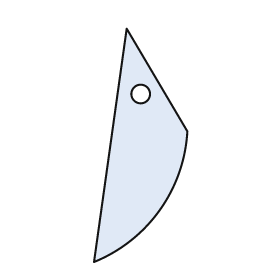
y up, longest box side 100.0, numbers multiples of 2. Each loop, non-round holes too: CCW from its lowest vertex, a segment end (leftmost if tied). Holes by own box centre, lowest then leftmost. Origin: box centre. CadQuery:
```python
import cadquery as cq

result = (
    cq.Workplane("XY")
    .moveTo(-20.0, -50.0)
    .threePointArc((8.0, -28.0), (20.0, 6.0))
    .lineTo(-6.0, 50.0)
    .close()
    .moveTo(0.0, 22.0)
    .circle(4.0)
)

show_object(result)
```